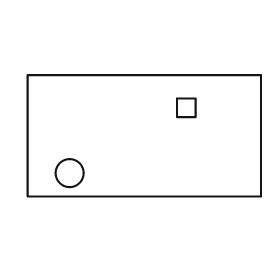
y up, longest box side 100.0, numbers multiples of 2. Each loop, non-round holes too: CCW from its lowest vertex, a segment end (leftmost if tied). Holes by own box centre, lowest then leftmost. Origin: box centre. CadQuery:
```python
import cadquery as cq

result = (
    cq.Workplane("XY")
    .moveTo(-50.0, -26.0)
    .lineTo(50.0, -26.0)
    .lineTo(50.0, 26.0)
    .lineTo(-50.0, 26.0)
    .close()
    .moveTo(-32.0, -16.0)
    .circle(6.0)
    .moveTo(14.0, 8.0)
    .lineTo(22.0, 8.0)
    .lineTo(22.0, 16.0)
    .lineTo(14.0, 16.0)
    .close()
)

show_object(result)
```